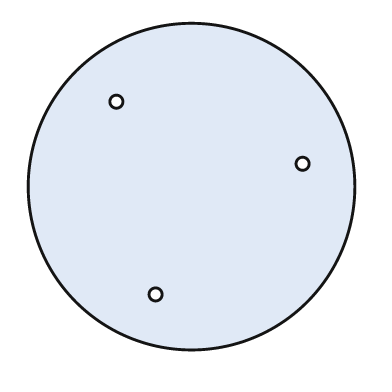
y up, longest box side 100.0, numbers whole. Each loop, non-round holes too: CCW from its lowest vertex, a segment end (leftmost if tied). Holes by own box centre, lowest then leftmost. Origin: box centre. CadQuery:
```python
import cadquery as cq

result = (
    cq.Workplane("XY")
    .moveTo(0.0, 0.0)
    .circle(50.0)
    .moveTo(-11.0, -33.0)
    .circle(2.0)
    .moveTo(34.0, 7.0)
    .circle(2.0)
    .moveTo(-23.0, 26.0)
    .circle(2.0)
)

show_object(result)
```